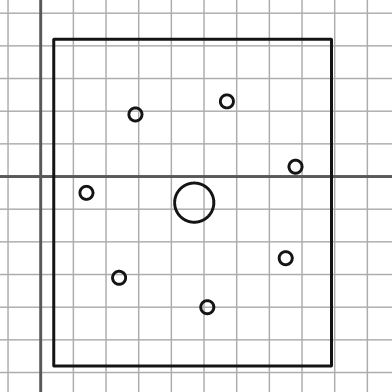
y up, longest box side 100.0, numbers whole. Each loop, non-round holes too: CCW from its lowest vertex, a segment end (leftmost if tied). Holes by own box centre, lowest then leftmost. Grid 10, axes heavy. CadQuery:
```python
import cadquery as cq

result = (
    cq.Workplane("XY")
    .moveTo(4.0, -58.0)
    .lineTo(89.0, -58.0)
    .lineTo(89.0, 42.0)
    .lineTo(4.0, 42.0)
    .close()
    .moveTo(51.0, -40.0)
    .circle(2.0)
    .moveTo(24.0, -31.0)
    .circle(2.0)
    .moveTo(75.0, -25.0)
    .circle(2.0)
    .moveTo(47.0, -8.0)
    .circle(6.0)
    .moveTo(14.0, -5.0)
    .circle(2.0)
    .moveTo(78.0, 3.0)
    .circle(2.0)
    .moveTo(29.0, 19.0)
    .circle(2.0)
    .moveTo(57.0, 23.0)
    .circle(2.0)
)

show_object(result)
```